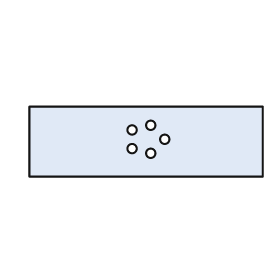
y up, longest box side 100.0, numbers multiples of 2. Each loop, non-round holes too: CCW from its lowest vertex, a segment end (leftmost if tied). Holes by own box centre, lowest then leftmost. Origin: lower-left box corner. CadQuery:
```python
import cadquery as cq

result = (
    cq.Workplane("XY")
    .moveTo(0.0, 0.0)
    .lineTo(100.0, 0.0)
    .lineTo(100.0, 30.0)
    .lineTo(0.0, 30.0)
    .close()
    .moveTo(52.0, 10.0)
    .circle(2.0)
    .moveTo(44.0, 12.0)
    .circle(2.0)
    .moveTo(58.0, 16.0)
    .circle(2.0)
    .moveTo(44.0, 20.0)
    .circle(2.0)
    .moveTo(52.0, 22.0)
    .circle(2.0)
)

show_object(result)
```